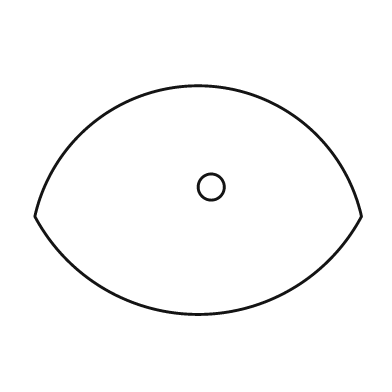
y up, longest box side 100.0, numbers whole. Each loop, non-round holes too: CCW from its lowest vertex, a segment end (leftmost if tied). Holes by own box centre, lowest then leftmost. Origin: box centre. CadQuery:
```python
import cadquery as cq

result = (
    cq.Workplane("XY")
    .moveTo(-50.0, -5.0)
    .threePointArc((0.0, -35.0), (50.0, -5.0))
    .threePointArc((0.0, 35.0), (-50.0, -5.0))
    .close()
    .moveTo(4.0, 4.0)
    .circle(4.0)
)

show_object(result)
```